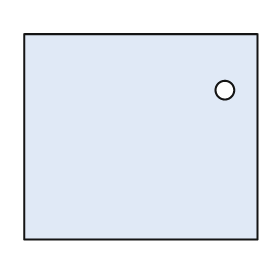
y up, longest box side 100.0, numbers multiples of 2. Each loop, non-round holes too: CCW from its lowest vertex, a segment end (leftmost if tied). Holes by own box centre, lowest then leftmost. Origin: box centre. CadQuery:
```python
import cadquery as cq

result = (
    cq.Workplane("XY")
    .moveTo(-50.0, -44.0)
    .lineTo(50.0, -44.0)
    .lineTo(50.0, 44.0)
    .lineTo(-50.0, 44.0)
    .close()
    .moveTo(36.0, 20.0)
    .circle(4.0)
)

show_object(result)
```